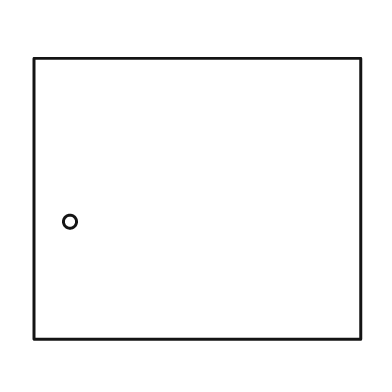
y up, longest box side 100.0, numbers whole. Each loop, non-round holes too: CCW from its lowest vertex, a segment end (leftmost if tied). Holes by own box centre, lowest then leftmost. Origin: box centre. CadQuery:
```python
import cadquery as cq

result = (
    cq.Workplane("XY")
    .moveTo(-50.0, -43.0)
    .lineTo(50.0, -43.0)
    .lineTo(50.0, 43.0)
    .lineTo(-50.0, 43.0)
    .close()
    .moveTo(-39.0, -7.0)
    .circle(2.0)
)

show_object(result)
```